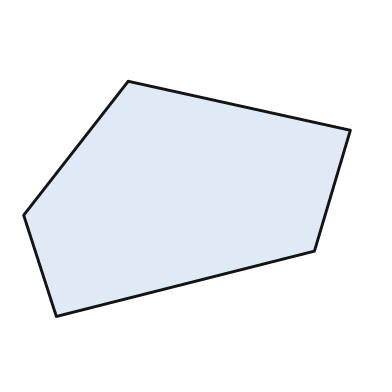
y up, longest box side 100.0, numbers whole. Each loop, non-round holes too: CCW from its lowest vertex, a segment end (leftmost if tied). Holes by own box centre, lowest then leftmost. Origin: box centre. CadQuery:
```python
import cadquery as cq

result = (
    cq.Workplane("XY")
    .moveTo(-40.0, -36.0)
    .lineTo(39.0, -16.0)
    .lineTo(50.0, 21.0)
    .lineTo(-18.0, 36.0)
    .lineTo(-50.0, -5.0)
    .close()
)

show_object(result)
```